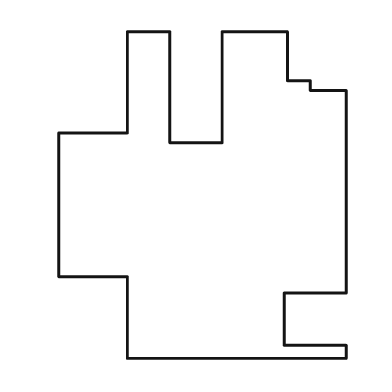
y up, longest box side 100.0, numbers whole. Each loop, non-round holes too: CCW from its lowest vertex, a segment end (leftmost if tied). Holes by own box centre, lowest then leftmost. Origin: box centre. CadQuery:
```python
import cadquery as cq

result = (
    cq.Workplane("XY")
    .moveTo(-23.0, -50.0)
    .lineTo(44.0, -50.0)
    .lineTo(44.0, -46.0)
    .lineTo(25.0, -46.0)
    .lineTo(25.0, -30.0)
    .lineTo(44.0, -30.0)
    .lineTo(44.0, 32.0)
    .lineTo(33.0, 32.0)
    .lineTo(33.0, 35.0)
    .lineTo(26.0, 35.0)
    .lineTo(26.0, 50.0)
    .lineTo(6.0, 50.0)
    .lineTo(6.0, 16.0)
    .lineTo(-10.0, 16.0)
    .lineTo(-10.0, 50.0)
    .lineTo(-23.0, 50.0)
    .lineTo(-23.0, 19.0)
    .lineTo(-44.0, 19.0)
    .lineTo(-44.0, -25.0)
    .lineTo(-23.0, -25.0)
    .close()
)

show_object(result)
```